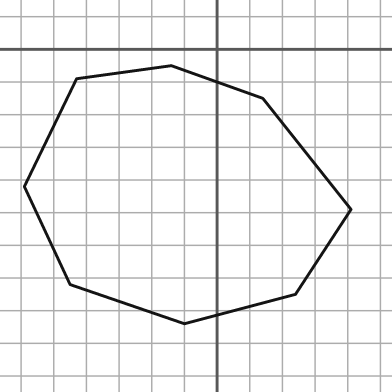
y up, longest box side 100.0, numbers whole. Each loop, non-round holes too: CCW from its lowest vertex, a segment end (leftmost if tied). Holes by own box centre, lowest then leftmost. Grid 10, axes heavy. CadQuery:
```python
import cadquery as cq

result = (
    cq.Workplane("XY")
    .moveTo(-10.0, -84.0)
    .lineTo(24.0, -75.0)
    .lineTo(41.0, -49.0)
    .lineTo(14.0, -15.0)
    .lineTo(-14.0, -5.0)
    .lineTo(-43.0, -9.0)
    .lineTo(-59.0, -42.0)
    .lineTo(-45.0, -72.0)
    .close()
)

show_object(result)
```